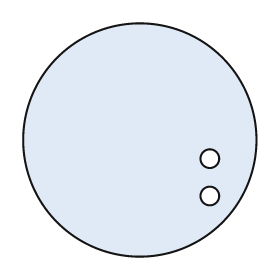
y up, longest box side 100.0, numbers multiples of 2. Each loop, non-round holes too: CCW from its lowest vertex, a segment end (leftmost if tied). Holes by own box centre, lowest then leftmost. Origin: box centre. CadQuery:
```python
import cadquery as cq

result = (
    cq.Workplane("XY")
    .moveTo(0.0, 0.0)
    .circle(50.0)
    .moveTo(30.0, -24.0)
    .circle(4.0)
    .moveTo(30.0, -8.0)
    .circle(4.0)
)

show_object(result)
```